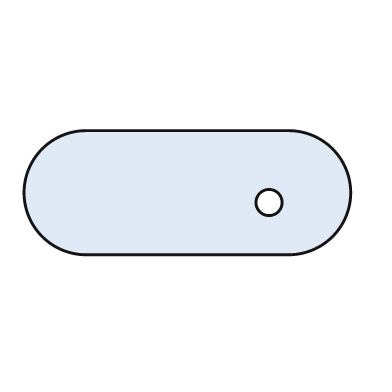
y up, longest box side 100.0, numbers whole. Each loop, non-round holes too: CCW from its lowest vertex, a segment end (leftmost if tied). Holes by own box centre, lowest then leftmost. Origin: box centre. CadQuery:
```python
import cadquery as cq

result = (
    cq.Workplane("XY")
    .moveTo(-31.0, -19.0)
    .lineTo(31.0, -19.0)
    .threePointArc((50.0, 0.0), (31.0, 19.0))
    .lineTo(-31.0, 19.0)
    .threePointArc((-50.0, 0.0), (-31.0, -19.0))
    .close()
    .moveTo(25.0, -3.0)
    .circle(4.0)
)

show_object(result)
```